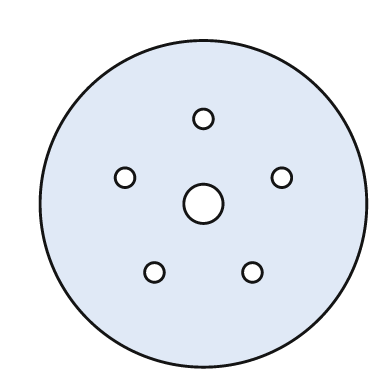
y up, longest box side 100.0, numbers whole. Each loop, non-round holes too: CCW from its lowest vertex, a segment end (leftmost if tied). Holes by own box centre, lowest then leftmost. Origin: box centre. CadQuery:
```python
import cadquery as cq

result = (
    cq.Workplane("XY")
    .moveTo(0.0, 0.0)
    .circle(50.0)
    .moveTo(-15.0, -21.0)
    .circle(3.0)
    .moveTo(15.0, -21.0)
    .circle(3.0)
    .moveTo(0.0, 0.0)
    .circle(6.0)
    .moveTo(-24.0, 8.0)
    .circle(3.0)
    .moveTo(24.0, 8.0)
    .circle(3.0)
    .moveTo(0.0, 26.0)
    .circle(3.0)
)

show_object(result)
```